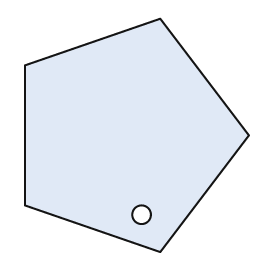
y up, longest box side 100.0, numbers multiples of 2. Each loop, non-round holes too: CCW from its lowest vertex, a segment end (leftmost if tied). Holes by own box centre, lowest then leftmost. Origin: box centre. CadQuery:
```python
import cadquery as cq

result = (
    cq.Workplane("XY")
    .moveTo(10.0, -50.0)
    .lineTo(48.0, 0.0)
    .lineTo(10.0, 50.0)
    .lineTo(-48.0, 30.0)
    .lineTo(-48.0, -30.0)
    .close()
    .moveTo(2.0, -34.0)
    .circle(4.0)
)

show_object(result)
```